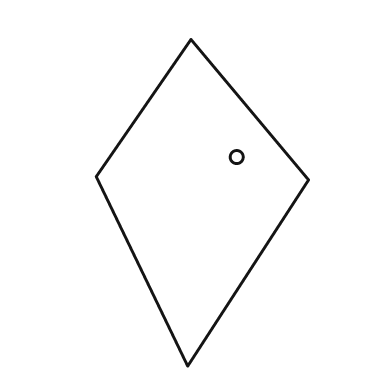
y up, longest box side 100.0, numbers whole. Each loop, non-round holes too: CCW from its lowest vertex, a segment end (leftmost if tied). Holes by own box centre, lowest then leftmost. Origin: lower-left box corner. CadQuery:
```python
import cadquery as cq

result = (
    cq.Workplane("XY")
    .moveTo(28.0, 0.0)
    .lineTo(65.0, 57.0)
    .lineTo(29.0, 100.0)
    .lineTo(0.0, 58.0)
    .close()
    .moveTo(43.0, 64.0)
    .circle(2.0)
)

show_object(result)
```